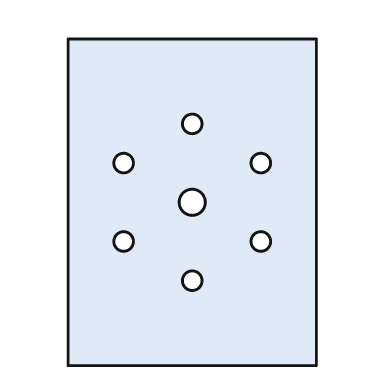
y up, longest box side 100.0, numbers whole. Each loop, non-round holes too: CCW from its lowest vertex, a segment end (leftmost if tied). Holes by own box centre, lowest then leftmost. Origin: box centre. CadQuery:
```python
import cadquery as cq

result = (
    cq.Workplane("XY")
    .moveTo(-38.0, -50.0)
    .lineTo(38.0, -50.0)
    .lineTo(38.0, 50.0)
    .lineTo(-38.0, 50.0)
    .close()
    .moveTo(0.0, -24.0)
    .circle(3.0)
    .moveTo(-21.0, -12.0)
    .circle(3.0)
    .moveTo(21.0, -12.0)
    .circle(3.0)
    .moveTo(0.0, 0.0)
    .circle(4.0)
    .moveTo(-21.0, 12.0)
    .circle(3.0)
    .moveTo(21.0, 12.0)
    .circle(3.0)
    .moveTo(0.0, 24.0)
    .circle(3.0)
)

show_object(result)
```